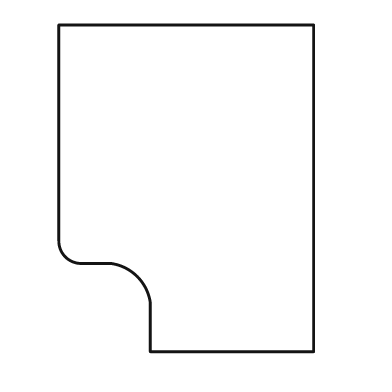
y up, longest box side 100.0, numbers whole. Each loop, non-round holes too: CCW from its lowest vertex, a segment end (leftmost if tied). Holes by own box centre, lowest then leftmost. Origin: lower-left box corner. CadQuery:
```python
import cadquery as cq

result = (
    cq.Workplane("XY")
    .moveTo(28.0, 0.0)
    .lineTo(78.0, 0.0)
    .lineTo(78.0, 100.0)
    .lineTo(0.0, 100.0)
    .lineTo(0.0, 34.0)
    .threePointArc((2.0, 29.0), (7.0, 27.0))
    .lineTo(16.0, 27.0)
    .threePointArc((24.0, 23.0), (28.0, 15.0))
    .close()
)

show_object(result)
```